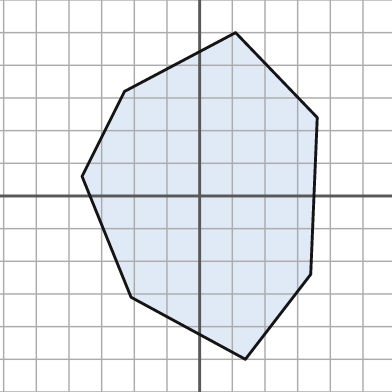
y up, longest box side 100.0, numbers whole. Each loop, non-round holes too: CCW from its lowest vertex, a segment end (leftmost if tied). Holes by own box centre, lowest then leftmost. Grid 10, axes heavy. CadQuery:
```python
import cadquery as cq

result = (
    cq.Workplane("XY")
    .moveTo(14.0, -50.0)
    .lineTo(34.0, -24.0)
    .lineTo(36.0, 24.0)
    .lineTo(11.0, 50.0)
    .lineTo(-23.0, 32.0)
    .lineTo(-36.0, 6.0)
    .lineTo(-21.0, -31.0)
    .close()
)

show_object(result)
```